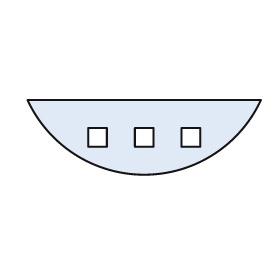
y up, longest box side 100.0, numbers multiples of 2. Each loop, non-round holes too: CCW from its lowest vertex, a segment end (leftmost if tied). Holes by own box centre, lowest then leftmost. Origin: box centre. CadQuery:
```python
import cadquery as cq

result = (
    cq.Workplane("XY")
    .moveTo(-50.0, 16.0)
    .threePointArc((0.0, -16.0), (50.0, 16.0))
    .close()
    .moveTo(-24.0, -4.0)
    .lineTo(-16.0, -4.0)
    .lineTo(-16.0, 4.0)
    .lineTo(-24.0, 4.0)
    .close()
    .moveTo(-4.0, -4.0)
    .lineTo(4.0, -4.0)
    .lineTo(4.0, 4.0)
    .lineTo(-4.0, 4.0)
    .close()
    .moveTo(16.0, -4.0)
    .lineTo(24.0, -4.0)
    .lineTo(24.0, 4.0)
    .lineTo(16.0, 4.0)
    .close()
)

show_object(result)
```